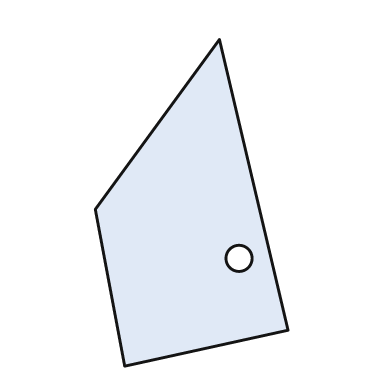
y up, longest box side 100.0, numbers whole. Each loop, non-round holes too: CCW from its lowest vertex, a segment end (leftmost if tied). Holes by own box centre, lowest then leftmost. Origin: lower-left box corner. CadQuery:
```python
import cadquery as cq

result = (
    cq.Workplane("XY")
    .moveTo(9.0, 0.0)
    .lineTo(59.0, 11.0)
    .lineTo(38.0, 100.0)
    .lineTo(0.0, 48.0)
    .close()
    .moveTo(44.0, 33.0)
    .circle(4.0)
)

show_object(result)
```